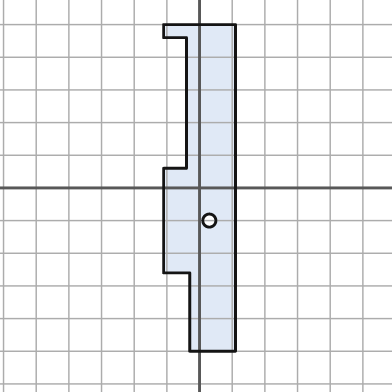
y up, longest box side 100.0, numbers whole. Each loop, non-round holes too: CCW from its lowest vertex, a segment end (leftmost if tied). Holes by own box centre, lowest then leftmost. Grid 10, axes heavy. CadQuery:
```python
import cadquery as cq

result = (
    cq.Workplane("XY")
    .moveTo(-3.0, -50.0)
    .lineTo(11.0, -50.0)
    .lineTo(11.0, 50.0)
    .lineTo(-11.0, 50.0)
    .lineTo(-11.0, 46.0)
    .lineTo(-4.0, 46.0)
    .lineTo(-4.0, 6.0)
    .lineTo(-11.0, 6.0)
    .lineTo(-11.0, -26.0)
    .lineTo(-3.0, -26.0)
    .close()
    .moveTo(3.0, -10.0)
    .circle(2.0)
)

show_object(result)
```